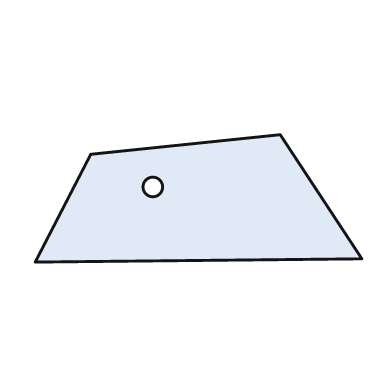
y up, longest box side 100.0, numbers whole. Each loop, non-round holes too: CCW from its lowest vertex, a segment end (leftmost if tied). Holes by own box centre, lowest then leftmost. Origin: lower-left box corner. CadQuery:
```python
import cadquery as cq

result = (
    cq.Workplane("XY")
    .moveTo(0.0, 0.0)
    .lineTo(100.0, 1.0)
    .lineTo(75.0, 39.0)
    .lineTo(17.0, 33.0)
    .close()
    .moveTo(36.0, 23.0)
    .circle(3.0)
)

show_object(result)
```